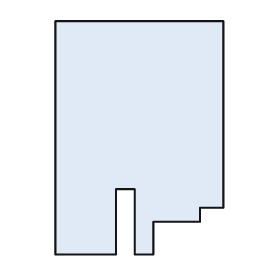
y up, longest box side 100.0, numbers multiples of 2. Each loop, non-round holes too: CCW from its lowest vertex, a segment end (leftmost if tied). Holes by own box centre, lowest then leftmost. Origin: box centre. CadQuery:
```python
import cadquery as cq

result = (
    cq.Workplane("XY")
    .moveTo(-36.0, -50.0)
    .lineTo(-10.0, -50.0)
    .lineTo(-10.0, -22.0)
    .lineTo(-2.0, -22.0)
    .lineTo(-2.0, -50.0)
    .lineTo(6.0, -50.0)
    .lineTo(6.0, -36.0)
    .lineTo(26.0, -36.0)
    .lineTo(26.0, -30.0)
    .lineTo(36.0, -30.0)
    .lineTo(36.0, 50.0)
    .lineTo(-36.0, 50.0)
    .close()
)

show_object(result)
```